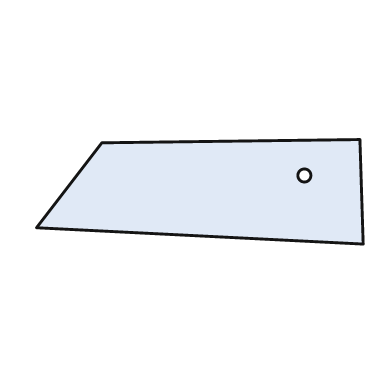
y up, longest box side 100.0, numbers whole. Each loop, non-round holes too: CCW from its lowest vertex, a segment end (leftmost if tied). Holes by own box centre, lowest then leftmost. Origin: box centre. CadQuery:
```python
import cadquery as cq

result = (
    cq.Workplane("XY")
    .moveTo(50.0, -16.0)
    .lineTo(49.0, 16.0)
    .lineTo(-30.0, 15.0)
    .lineTo(-50.0, -11.0)
    .close()
    .moveTo(32.0, 5.0)
    .circle(2.0)
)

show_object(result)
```